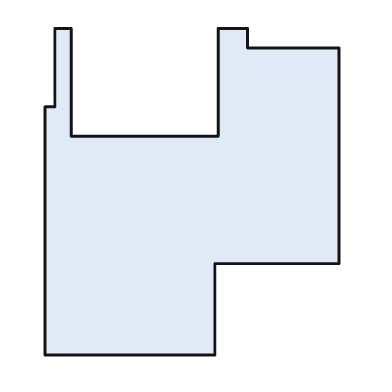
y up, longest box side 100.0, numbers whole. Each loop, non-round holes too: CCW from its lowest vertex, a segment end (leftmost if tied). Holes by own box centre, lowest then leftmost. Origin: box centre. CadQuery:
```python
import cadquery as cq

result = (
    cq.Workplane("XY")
    .moveTo(-45.0, -50.0)
    .lineTo(7.0, -50.0)
    .lineTo(7.0, -22.0)
    .lineTo(45.0, -22.0)
    .lineTo(45.0, 44.0)
    .lineTo(17.0, 44.0)
    .lineTo(17.0, 50.0)
    .lineTo(8.0, 50.0)
    .lineTo(8.0, 17.0)
    .lineTo(-37.0, 17.0)
    .lineTo(-37.0, 50.0)
    .lineTo(-42.0, 50.0)
    .lineTo(-42.0, 26.0)
    .lineTo(-45.0, 26.0)
    .close()
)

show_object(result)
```